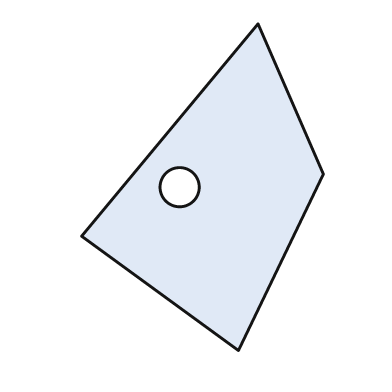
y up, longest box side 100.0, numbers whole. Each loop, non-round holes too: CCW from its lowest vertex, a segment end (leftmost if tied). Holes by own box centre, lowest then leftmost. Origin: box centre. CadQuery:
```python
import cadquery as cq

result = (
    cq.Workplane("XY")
    .moveTo(11.0, -50.0)
    .lineTo(37.0, 4.0)
    .lineTo(17.0, 50.0)
    .lineTo(-37.0, -15.0)
    .close()
    .moveTo(-7.0, 0.0)
    .circle(6.0)
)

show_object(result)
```